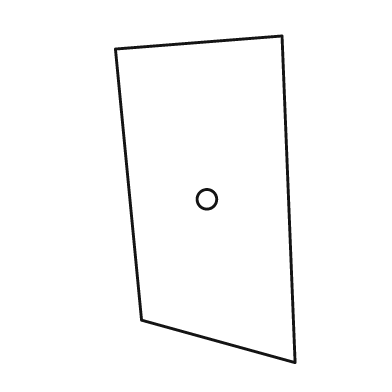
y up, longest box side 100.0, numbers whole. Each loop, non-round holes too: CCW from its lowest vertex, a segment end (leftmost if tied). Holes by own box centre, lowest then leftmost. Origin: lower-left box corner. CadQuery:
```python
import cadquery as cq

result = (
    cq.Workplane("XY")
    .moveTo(55.0, 0.0)
    .lineTo(51.0, 100.0)
    .lineTo(0.0, 96.0)
    .lineTo(8.0, 13.0)
    .close()
    .moveTo(28.0, 50.0)
    .circle(3.0)
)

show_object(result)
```